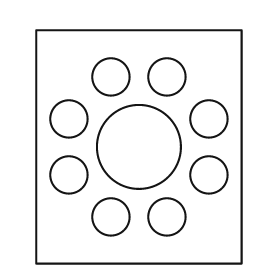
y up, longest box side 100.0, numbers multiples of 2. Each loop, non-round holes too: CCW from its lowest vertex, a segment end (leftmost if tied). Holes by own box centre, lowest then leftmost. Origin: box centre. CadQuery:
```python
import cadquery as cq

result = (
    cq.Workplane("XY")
    .moveTo(-44.0, -50.0)
    .lineTo(44.0, -50.0)
    .lineTo(44.0, 50.0)
    .lineTo(-44.0, 50.0)
    .close()
    .moveTo(-12.0, -30.0)
    .circle(8.0)
    .moveTo(12.0, -30.0)
    .circle(8.0)
    .moveTo(-30.0, -12.0)
    .circle(8.0)
    .moveTo(30.0, -12.0)
    .circle(8.0)
    .moveTo(0.0, 0.0)
    .circle(18.0)
    .moveTo(-30.0, 12.0)
    .circle(8.0)
    .moveTo(30.0, 12.0)
    .circle(8.0)
    .moveTo(-12.0, 30.0)
    .circle(8.0)
    .moveTo(12.0, 30.0)
    .circle(8.0)
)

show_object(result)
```